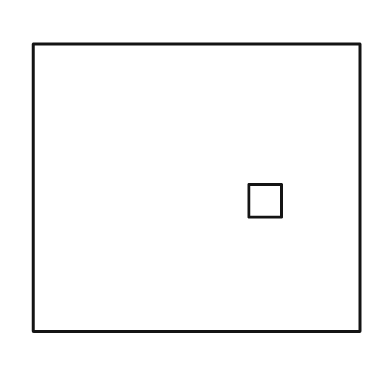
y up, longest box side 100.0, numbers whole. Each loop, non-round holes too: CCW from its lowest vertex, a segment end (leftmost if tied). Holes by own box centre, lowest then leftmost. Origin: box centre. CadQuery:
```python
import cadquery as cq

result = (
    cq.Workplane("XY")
    .moveTo(-50.0, -44.0)
    .lineTo(50.0, -44.0)
    .lineTo(50.0, 44.0)
    .lineTo(-50.0, 44.0)
    .close()
    .moveTo(16.0, -9.0)
    .lineTo(26.0, -9.0)
    .lineTo(26.0, 1.0)
    .lineTo(16.0, 1.0)
    .close()
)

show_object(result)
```